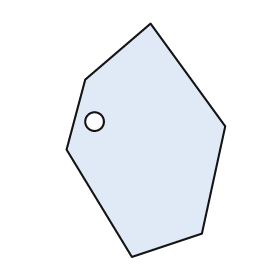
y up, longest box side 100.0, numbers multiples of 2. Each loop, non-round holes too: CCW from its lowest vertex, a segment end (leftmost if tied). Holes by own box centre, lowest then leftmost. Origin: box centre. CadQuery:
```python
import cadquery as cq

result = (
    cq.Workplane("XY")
    .moveTo(-6.0, -50.0)
    .lineTo(24.0, -40.0)
    .lineTo(34.0, 6.0)
    .lineTo(2.0, 50.0)
    .lineTo(-26.0, 26.0)
    .lineTo(-34.0, -4.0)
    .close()
    .moveTo(-22.0, 8.0)
    .circle(4.0)
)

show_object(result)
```